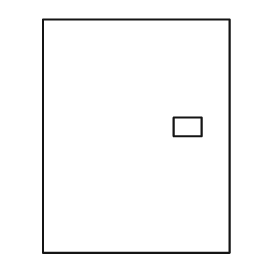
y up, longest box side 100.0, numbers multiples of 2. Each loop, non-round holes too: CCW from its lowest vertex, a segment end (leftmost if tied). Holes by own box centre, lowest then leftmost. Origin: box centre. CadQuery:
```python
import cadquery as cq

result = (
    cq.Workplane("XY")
    .moveTo(-40.0, -50.0)
    .lineTo(40.0, -50.0)
    .lineTo(40.0, 50.0)
    .lineTo(-40.0, 50.0)
    .close()
    .moveTo(16.0, 0.0)
    .lineTo(28.0, 0.0)
    .lineTo(28.0, 8.0)
    .lineTo(16.0, 8.0)
    .close()
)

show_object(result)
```